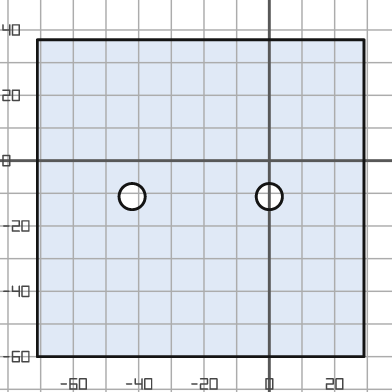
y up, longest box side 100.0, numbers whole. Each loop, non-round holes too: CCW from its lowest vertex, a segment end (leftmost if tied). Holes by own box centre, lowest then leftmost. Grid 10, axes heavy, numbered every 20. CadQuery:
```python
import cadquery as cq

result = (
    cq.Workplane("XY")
    .moveTo(-71.0, -60.0)
    .lineTo(29.0, -60.0)
    .lineTo(29.0, 37.0)
    .lineTo(-71.0, 37.0)
    .close()
    .moveTo(-42.0, -11.0)
    .circle(4.0)
    .moveTo(0.0, -11.0)
    .circle(4.0)
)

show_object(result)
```